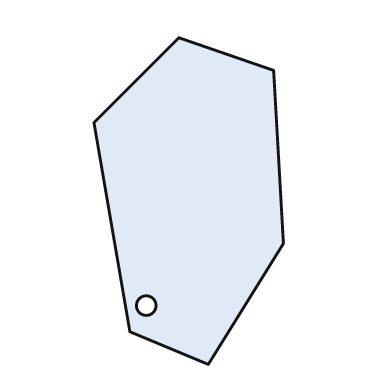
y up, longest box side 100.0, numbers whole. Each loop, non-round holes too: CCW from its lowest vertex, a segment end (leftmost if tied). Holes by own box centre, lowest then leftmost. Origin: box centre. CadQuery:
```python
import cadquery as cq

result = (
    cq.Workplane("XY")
    .moveTo(6.0, -50.0)
    .lineTo(29.0, -13.0)
    .lineTo(26.0, 40.0)
    .lineTo(-3.0, 50.0)
    .lineTo(-29.0, 24.0)
    .lineTo(-18.0, -40.0)
    .close()
    .moveTo(-13.0, -32.0)
    .circle(3.0)
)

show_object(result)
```